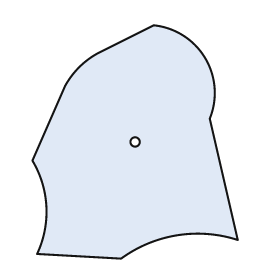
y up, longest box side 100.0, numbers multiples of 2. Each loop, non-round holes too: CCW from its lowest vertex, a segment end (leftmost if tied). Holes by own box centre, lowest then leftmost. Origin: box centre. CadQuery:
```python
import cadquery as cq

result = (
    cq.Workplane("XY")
    .moveTo(-6.0, -50.0)
    .threePointArc((18.0, -40.0), (44.0, -42.0))
    .lineTo(32.0, 10.0)
    .threePointArc((30.0, 36.0), (8.0, 50.0))
    .lineTo(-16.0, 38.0)
    .threePointArc((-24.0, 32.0), (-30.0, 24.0))
    .lineTo(-44.0, -8.0)
    .threePointArc((-38.0, -28.0), (-42.0, -48.0))
    .close()
    .moveTo(0.0, 0.0)
    .circle(2.0)
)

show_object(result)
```